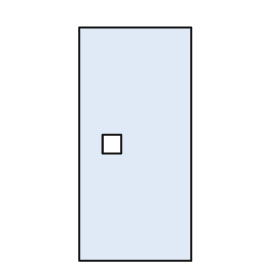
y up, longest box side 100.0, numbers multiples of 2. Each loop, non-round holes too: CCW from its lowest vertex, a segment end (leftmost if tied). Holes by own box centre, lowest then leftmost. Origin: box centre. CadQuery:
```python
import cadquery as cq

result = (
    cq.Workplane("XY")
    .moveTo(-24.0, -50.0)
    .lineTo(24.0, -50.0)
    .lineTo(24.0, 50.0)
    .lineTo(-24.0, 50.0)
    .close()
    .moveTo(-14.0, -4.0)
    .lineTo(-6.0, -4.0)
    .lineTo(-6.0, 4.0)
    .lineTo(-14.0, 4.0)
    .close()
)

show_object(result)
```